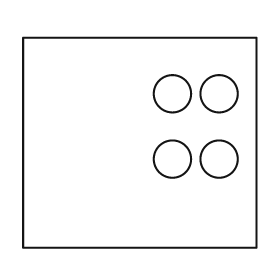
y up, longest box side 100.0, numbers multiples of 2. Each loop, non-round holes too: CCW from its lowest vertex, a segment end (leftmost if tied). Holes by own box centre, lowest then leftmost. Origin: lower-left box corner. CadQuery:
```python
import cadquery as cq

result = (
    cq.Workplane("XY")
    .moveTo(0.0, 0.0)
    .lineTo(100.0, 0.0)
    .lineTo(100.0, 90.0)
    .lineTo(0.0, 90.0)
    .close()
    .moveTo(64.0, 38.0)
    .circle(8.0)
    .moveTo(84.0, 38.0)
    .circle(8.0)
    .moveTo(64.0, 66.0)
    .circle(8.0)
    .moveTo(84.0, 66.0)
    .circle(8.0)
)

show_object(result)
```